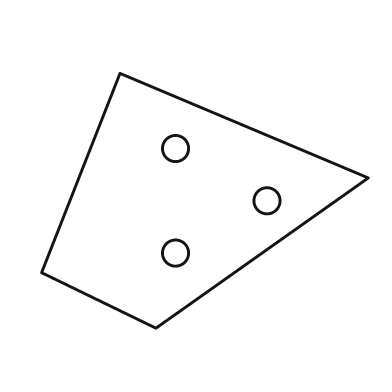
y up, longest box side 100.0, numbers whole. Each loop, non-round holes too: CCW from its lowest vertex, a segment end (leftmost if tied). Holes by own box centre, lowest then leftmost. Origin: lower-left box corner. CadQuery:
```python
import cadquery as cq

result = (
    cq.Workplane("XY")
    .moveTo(35.0, 0.0)
    .lineTo(100.0, 46.0)
    .lineTo(24.0, 78.0)
    .lineTo(0.0, 17.0)
    .close()
    .moveTo(41.0, 23.0)
    .circle(4.0)
    .moveTo(69.0, 39.0)
    .circle(4.0)
    .moveTo(41.0, 55.0)
    .circle(4.0)
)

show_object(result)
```